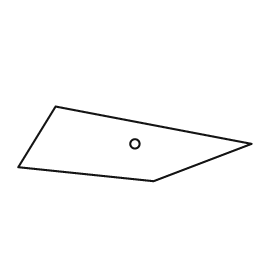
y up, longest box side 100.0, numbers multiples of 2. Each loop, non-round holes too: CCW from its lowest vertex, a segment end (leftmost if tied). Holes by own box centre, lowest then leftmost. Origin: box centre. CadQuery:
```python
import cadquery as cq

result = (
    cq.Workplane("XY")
    .moveTo(8.0, -16.0)
    .lineTo(50.0, 0.0)
    .lineTo(-34.0, 16.0)
    .lineTo(-50.0, -10.0)
    .close()
    .moveTo(0.0, 0.0)
    .circle(2.0)
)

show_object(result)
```